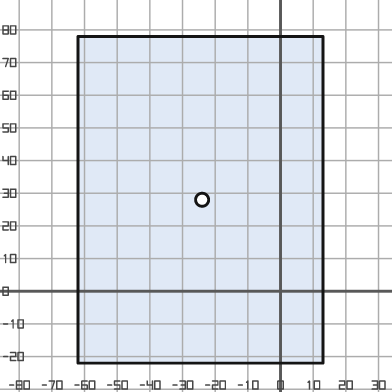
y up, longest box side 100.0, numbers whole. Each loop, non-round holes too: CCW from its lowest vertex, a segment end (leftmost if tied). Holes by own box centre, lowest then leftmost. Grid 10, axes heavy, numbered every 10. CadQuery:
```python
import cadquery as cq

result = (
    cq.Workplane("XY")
    .moveTo(-62.0, -22.0)
    .lineTo(13.0, -22.0)
    .lineTo(13.0, 78.0)
    .lineTo(-62.0, 78.0)
    .close()
    .moveTo(-24.0, 28.0)
    .circle(2.0)
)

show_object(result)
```